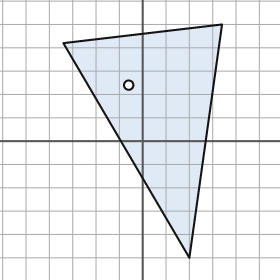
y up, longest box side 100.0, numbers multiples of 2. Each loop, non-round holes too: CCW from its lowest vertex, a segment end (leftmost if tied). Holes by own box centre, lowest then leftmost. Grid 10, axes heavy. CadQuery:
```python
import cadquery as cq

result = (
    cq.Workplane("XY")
    .moveTo(20.0, -50.0)
    .lineTo(34.0, 50.0)
    .lineTo(-34.0, 42.0)
    .close()
    .moveTo(-6.0, 24.0)
    .circle(2.0)
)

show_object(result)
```